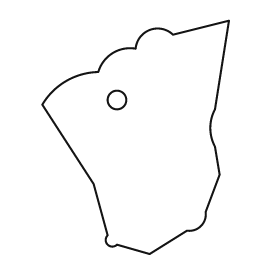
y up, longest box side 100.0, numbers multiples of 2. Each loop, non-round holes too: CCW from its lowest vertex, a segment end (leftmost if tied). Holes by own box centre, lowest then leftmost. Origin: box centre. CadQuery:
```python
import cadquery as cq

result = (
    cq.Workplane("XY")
    .moveTo(6.0, -50.0)
    .lineTo(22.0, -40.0)
    .threePointArc((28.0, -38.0), (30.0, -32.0))
    .lineTo(36.0, -16.0)
    .lineTo(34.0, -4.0)
    .threePointArc((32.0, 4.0), (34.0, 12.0))
    .lineTo(40.0, 50.0)
    .lineTo(16.0, 44.0)
    .threePointArc((6.0, 46.0), (0.0, 38.0))
    .threePointArc((-10.0, 36.0), (-16.0, 28.0))
    .threePointArc((-30.0, 24.0), (-40.0, 14.0))
    .lineTo(-18.0, -20.0)
    .lineTo(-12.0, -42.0)
    .threePointArc((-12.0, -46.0), (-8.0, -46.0))
    .close()
    .moveTo(-8.0, 16.0)
    .circle(4.0)
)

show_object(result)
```